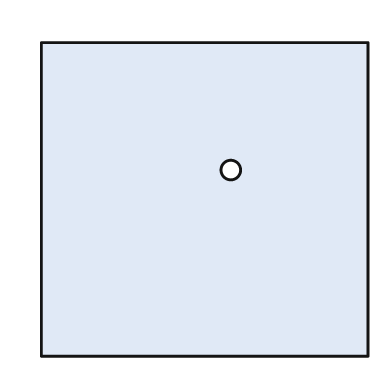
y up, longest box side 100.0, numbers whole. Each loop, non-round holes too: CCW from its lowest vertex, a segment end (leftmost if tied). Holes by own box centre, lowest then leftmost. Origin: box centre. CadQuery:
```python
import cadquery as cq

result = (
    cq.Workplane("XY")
    .moveTo(-50.0, -48.0)
    .lineTo(50.0, -48.0)
    .lineTo(50.0, 48.0)
    .lineTo(-50.0, 48.0)
    .close()
    .moveTo(8.0, 9.0)
    .circle(3.0)
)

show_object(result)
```